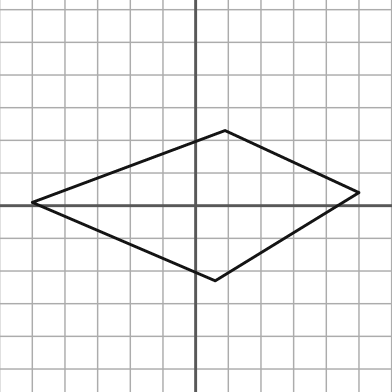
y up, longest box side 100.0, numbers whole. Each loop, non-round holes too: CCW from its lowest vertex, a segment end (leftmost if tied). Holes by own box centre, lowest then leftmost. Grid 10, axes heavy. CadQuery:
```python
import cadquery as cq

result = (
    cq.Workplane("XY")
    .moveTo(6.0, -23.0)
    .lineTo(50.0, 4.0)
    .lineTo(9.0, 23.0)
    .lineTo(-50.0, 1.0)
    .close()
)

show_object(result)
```